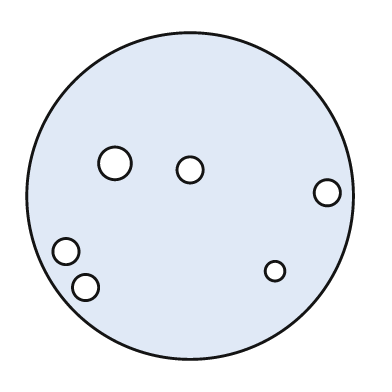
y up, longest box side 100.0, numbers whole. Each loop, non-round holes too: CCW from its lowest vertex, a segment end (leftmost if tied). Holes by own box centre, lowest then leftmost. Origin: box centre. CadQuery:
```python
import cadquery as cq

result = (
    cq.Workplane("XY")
    .moveTo(0.0, 0.0)
    .circle(50.0)
    .moveTo(-32.0, -28.0)
    .circle(4.0)
    .moveTo(26.0, -23.0)
    .circle(3.0)
    .moveTo(-38.0, -17.0)
    .circle(4.0)
    .moveTo(42.0, 1.0)
    .circle(4.0)
    .moveTo(0.0, 8.0)
    .circle(4.0)
    .moveTo(-23.0, 10.0)
    .circle(5.0)
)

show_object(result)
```